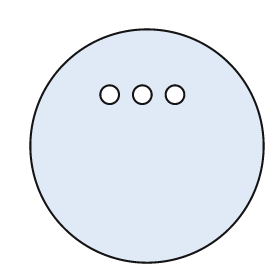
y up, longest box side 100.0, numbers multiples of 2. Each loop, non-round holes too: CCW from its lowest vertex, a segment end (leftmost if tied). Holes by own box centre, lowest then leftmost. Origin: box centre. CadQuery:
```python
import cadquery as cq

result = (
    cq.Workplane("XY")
    .moveTo(0.0, 0.0)
    .circle(50.0)
    .moveTo(-16.0, 22.0)
    .circle(4.0)
    .moveTo(-2.0, 22.0)
    .circle(4.0)
    .moveTo(12.0, 22.0)
    .circle(4.0)
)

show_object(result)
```